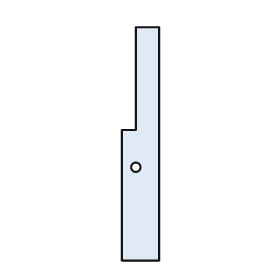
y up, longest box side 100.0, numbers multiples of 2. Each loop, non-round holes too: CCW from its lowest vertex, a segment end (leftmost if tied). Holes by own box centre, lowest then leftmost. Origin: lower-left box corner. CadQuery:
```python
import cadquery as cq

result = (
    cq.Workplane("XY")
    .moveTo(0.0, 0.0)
    .lineTo(16.0, 0.0)
    .lineTo(16.0, 100.0)
    .lineTo(6.0, 100.0)
    .lineTo(6.0, 56.0)
    .lineTo(0.0, 56.0)
    .close()
    .moveTo(6.0, 40.0)
    .circle(2.0)
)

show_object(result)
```